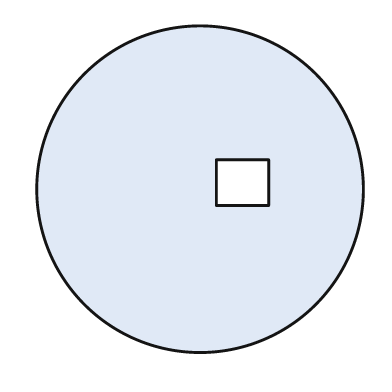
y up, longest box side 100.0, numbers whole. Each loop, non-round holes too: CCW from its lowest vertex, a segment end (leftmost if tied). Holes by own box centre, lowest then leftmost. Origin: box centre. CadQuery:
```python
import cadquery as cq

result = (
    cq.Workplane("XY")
    .moveTo(0.0, 0.0)
    .circle(50.0)
    .moveTo(5.0, -5.0)
    .lineTo(21.0, -5.0)
    .lineTo(21.0, 9.0)
    .lineTo(5.0, 9.0)
    .close()
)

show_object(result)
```